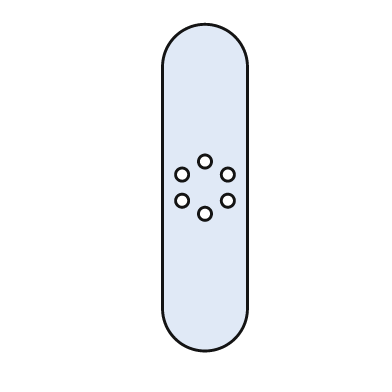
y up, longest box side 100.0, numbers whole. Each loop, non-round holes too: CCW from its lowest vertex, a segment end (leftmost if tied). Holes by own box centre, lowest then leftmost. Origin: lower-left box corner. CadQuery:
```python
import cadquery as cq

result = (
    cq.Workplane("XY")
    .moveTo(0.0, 13.0)
    .threePointArc((13.0, 0.0), (26.0, 13.0))
    .lineTo(26.0, 87.0)
    .threePointArc((13.0, 100.0), (0.0, 87.0))
    .close()
    .moveTo(13.0, 42.0)
    .circle(2.0)
    .moveTo(6.0, 46.0)
    .circle(2.0)
    .moveTo(20.0, 46.0)
    .circle(2.0)
    .moveTo(6.0, 54.0)
    .circle(2.0)
    .moveTo(20.0, 54.0)
    .circle(2.0)
    .moveTo(13.0, 58.0)
    .circle(2.0)
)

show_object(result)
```